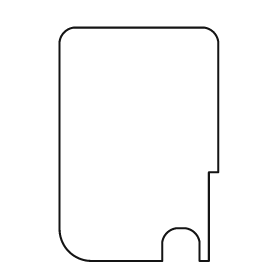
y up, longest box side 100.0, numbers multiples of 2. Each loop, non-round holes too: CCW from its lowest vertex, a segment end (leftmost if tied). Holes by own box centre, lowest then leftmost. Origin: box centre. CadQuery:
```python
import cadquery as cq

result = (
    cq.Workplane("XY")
    .moveTo(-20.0, -50.0)
    .lineTo(10.0, -50.0)
    .lineTo(10.0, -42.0)
    .threePointArc((12.0, -38.0), (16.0, -36.0))
    .lineTo(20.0, -36.0)
    .threePointArc((24.0, -38.0), (26.0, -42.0))
    .lineTo(26.0, -50.0)
    .lineTo(30.0, -50.0)
    .lineTo(30.0, -12.0)
    .lineTo(34.0, -12.0)
    .lineTo(34.0, 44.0)
    .threePointArc((32.0, 48.0), (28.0, 50.0))
    .lineTo(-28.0, 50.0)
    .threePointArc((-32.0, 48.0), (-34.0, 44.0))
    .lineTo(-34.0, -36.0)
    .threePointArc((-30.0, -46.0), (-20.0, -50.0))
    .close()
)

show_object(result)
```